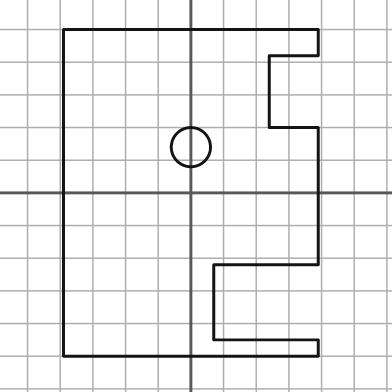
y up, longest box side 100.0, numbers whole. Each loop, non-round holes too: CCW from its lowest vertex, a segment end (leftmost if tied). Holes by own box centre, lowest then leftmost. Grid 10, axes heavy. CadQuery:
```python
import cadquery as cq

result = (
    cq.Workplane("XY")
    .moveTo(-39.0, -50.0)
    .lineTo(39.0, -50.0)
    .lineTo(39.0, -45.0)
    .lineTo(7.0, -45.0)
    .lineTo(7.0, -22.0)
    .lineTo(39.0, -22.0)
    .lineTo(39.0, 20.0)
    .lineTo(24.0, 20.0)
    .lineTo(24.0, 42.0)
    .lineTo(39.0, 42.0)
    .lineTo(39.0, 50.0)
    .lineTo(-39.0, 50.0)
    .close()
    .moveTo(0.0, 14.0)
    .circle(6.0)
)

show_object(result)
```